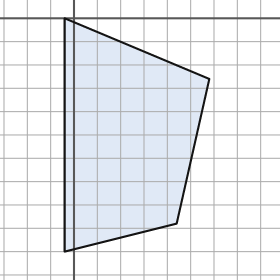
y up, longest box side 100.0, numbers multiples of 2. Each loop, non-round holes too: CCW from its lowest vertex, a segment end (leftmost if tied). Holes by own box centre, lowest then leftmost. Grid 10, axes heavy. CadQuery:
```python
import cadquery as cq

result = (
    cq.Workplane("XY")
    .moveTo(-4.0, -100.0)
    .lineTo(44.0, -88.0)
    .lineTo(58.0, -26.0)
    .lineTo(-4.0, 0.0)
    .close()
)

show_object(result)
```